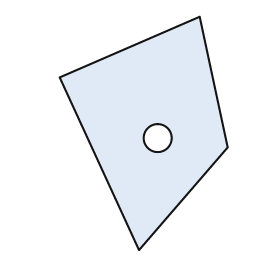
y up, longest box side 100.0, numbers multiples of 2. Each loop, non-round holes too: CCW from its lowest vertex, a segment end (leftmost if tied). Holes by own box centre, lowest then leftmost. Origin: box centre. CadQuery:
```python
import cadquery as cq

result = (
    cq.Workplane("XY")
    .moveTo(-2.0, -50.0)
    .lineTo(36.0, -6.0)
    .lineTo(24.0, 50.0)
    .lineTo(-36.0, 24.0)
    .close()
    .moveTo(6.0, -2.0)
    .circle(6.0)
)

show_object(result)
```